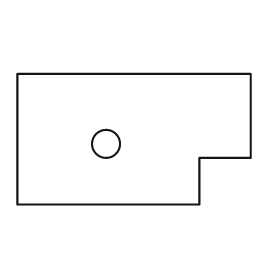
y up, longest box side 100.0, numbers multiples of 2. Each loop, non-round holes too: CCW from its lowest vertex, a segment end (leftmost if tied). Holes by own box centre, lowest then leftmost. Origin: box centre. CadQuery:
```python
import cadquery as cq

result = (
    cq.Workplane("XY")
    .moveTo(-50.0, -28.0)
    .lineTo(28.0, -28.0)
    .lineTo(28.0, -8.0)
    .lineTo(50.0, -8.0)
    .lineTo(50.0, 28.0)
    .lineTo(-50.0, 28.0)
    .close()
    .moveTo(-12.0, -2.0)
    .circle(6.0)
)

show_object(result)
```